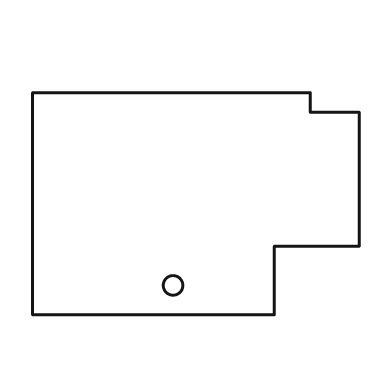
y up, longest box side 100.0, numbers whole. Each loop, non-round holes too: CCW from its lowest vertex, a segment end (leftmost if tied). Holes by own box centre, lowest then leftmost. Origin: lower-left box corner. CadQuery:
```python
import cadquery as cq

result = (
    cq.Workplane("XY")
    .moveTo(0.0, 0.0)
    .lineTo(74.0, 0.0)
    .lineTo(74.0, 21.0)
    .lineTo(100.0, 21.0)
    .lineTo(100.0, 62.0)
    .lineTo(85.0, 62.0)
    .lineTo(85.0, 68.0)
    .lineTo(0.0, 68.0)
    .close()
    .moveTo(43.0, 9.0)
    .circle(3.0)
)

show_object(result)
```